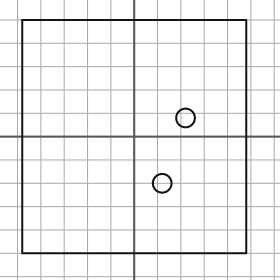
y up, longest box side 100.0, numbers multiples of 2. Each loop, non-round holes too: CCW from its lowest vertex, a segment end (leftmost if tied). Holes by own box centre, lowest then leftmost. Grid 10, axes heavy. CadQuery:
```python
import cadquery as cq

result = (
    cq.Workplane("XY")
    .moveTo(-48.0, -50.0)
    .lineTo(48.0, -50.0)
    .lineTo(48.0, 50.0)
    .lineTo(-48.0, 50.0)
    .close()
    .moveTo(12.0, -20.0)
    .circle(4.0)
    .moveTo(22.0, 8.0)
    .circle(4.0)
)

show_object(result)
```